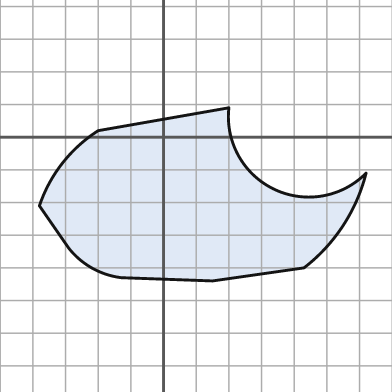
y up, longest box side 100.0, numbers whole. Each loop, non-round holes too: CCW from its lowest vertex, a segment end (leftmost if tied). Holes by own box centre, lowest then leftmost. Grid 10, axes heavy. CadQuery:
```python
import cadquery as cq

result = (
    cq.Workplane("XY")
    .moveTo(15.0, -44.0)
    .lineTo(43.0, -40.0)
    .threePointArc((55.0, -27.0), (62.0, -11.0))
    .threePointArc((34.0, -16.0), (20.0, 9.0))
    .lineTo(-20.0, 2.0)
    .threePointArc((-31.0, -8.0), (-38.0, -21.0))
    .lineTo(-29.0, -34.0)
    .threePointArc((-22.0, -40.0), (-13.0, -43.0))
    .close()
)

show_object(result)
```